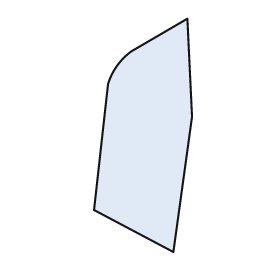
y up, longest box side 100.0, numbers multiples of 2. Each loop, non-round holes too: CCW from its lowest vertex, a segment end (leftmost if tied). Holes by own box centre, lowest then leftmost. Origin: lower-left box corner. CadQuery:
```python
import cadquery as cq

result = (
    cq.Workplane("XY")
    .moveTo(34.0, 0.0)
    .lineTo(42.0, 58.0)
    .lineTo(40.0, 100.0)
    .lineTo(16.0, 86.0)
    .threePointArc((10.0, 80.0), (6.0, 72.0))
    .lineTo(0.0, 18.0)
    .close()
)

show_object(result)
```